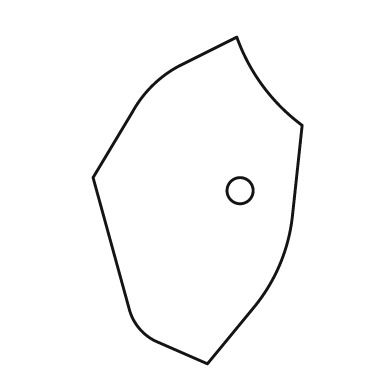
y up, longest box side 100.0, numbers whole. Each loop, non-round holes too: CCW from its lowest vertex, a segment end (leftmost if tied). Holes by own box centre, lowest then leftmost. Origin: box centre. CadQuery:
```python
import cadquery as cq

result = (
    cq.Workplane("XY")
    .moveTo(3.0, -50.0)
    .lineTo(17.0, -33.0)
    .threePointArc((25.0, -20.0), (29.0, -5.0))
    .lineTo(32.0, 23.0)
    .threePointArc((20.0, 35.0), (12.0, 50.0))
    .lineTo(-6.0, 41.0)
    .threePointArc((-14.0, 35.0), (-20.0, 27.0))
    .lineTo(-32.0, 7.0)
    .lineTo(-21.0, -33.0)
    .threePointArc((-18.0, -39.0), (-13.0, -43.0))
    .close()
    .moveTo(13.0, 3.0)
    .circle(4.0)
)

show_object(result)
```